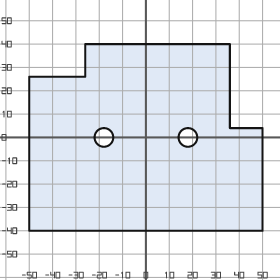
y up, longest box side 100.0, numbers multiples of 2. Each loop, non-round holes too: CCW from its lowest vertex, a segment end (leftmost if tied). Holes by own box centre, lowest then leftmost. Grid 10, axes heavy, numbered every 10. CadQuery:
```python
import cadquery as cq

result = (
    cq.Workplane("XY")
    .moveTo(-50.0, -40.0)
    .lineTo(50.0, -40.0)
    .lineTo(50.0, 4.0)
    .lineTo(36.0, 4.0)
    .lineTo(36.0, 40.0)
    .lineTo(-26.0, 40.0)
    .lineTo(-26.0, 26.0)
    .lineTo(-50.0, 26.0)
    .close()
    .moveTo(-18.0, 0.0)
    .circle(4.0)
    .moveTo(18.0, 0.0)
    .circle(4.0)
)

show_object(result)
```